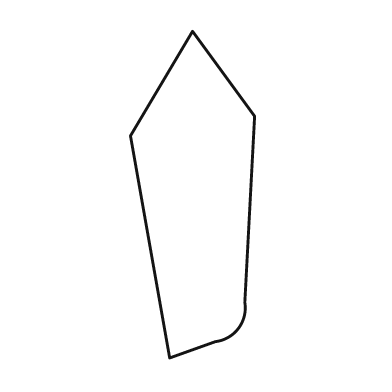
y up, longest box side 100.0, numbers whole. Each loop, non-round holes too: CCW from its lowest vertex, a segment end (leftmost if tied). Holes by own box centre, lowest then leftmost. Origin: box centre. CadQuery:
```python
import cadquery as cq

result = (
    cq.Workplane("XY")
    .moveTo(-7.0, -50.0)
    .lineTo(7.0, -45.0)
    .threePointArc((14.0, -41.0), (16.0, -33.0))
    .lineTo(19.0, 24.0)
    .lineTo(0.0, 50.0)
    .lineTo(-19.0, 18.0)
    .close()
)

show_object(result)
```